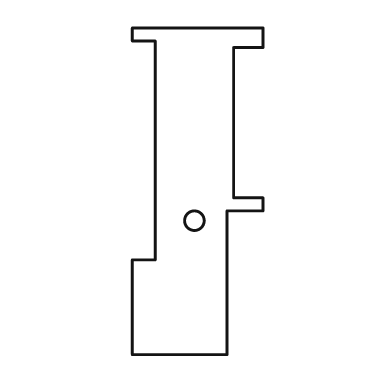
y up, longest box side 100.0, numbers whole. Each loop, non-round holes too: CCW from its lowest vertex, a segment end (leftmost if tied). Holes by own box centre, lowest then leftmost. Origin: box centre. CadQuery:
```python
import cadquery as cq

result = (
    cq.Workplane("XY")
    .moveTo(-20.0, -50.0)
    .lineTo(9.0, -50.0)
    .lineTo(9.0, -6.0)
    .lineTo(20.0, -6.0)
    .lineTo(20.0, -2.0)
    .lineTo(11.0, -2.0)
    .lineTo(11.0, 44.0)
    .lineTo(20.0, 44.0)
    .lineTo(20.0, 50.0)
    .lineTo(-20.0, 50.0)
    .lineTo(-20.0, 46.0)
    .lineTo(-13.0, 46.0)
    .lineTo(-13.0, -21.0)
    .lineTo(-20.0, -21.0)
    .close()
    .moveTo(-1.0, -9.0)
    .circle(3.0)
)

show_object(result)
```